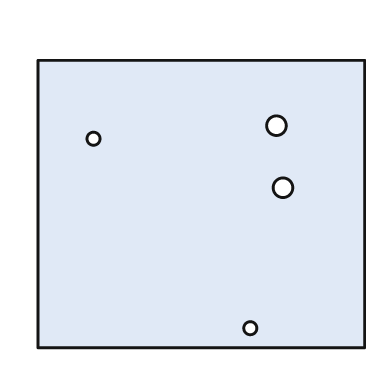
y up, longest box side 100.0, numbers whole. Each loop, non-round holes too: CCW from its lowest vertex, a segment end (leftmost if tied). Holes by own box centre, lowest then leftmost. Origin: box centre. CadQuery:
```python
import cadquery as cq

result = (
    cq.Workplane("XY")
    .moveTo(-50.0, -44.0)
    .lineTo(50.0, -44.0)
    .lineTo(50.0, 44.0)
    .lineTo(-50.0, 44.0)
    .close()
    .moveTo(15.0, -38.0)
    .circle(2.0)
    .moveTo(25.0, 5.0)
    .circle(3.0)
    .moveTo(-33.0, 20.0)
    .circle(2.0)
    .moveTo(23.0, 24.0)
    .circle(3.0)
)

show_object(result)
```